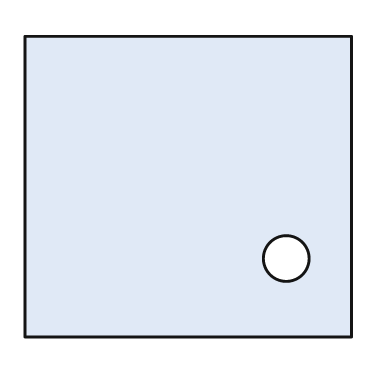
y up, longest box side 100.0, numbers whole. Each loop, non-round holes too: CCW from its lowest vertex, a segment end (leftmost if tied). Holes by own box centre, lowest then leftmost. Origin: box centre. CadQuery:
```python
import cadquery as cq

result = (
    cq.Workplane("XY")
    .moveTo(-50.0, -46.0)
    .lineTo(50.0, -46.0)
    .lineTo(50.0, 46.0)
    .lineTo(-50.0, 46.0)
    .close()
    .moveTo(30.0, -22.0)
    .circle(7.0)
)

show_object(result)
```